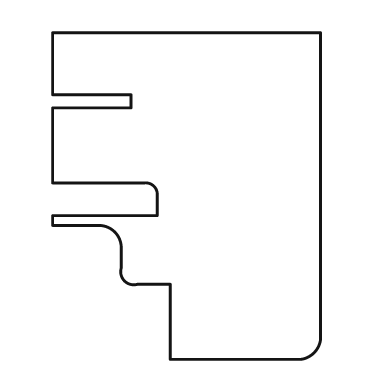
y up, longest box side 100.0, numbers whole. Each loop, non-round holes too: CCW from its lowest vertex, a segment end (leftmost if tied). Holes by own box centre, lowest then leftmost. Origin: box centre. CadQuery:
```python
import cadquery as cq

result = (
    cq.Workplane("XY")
    .moveTo(-5.0, -50.0)
    .lineTo(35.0, -50.0)
    .threePointArc((39.0, -48.0), (41.0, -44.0))
    .lineTo(41.0, 50.0)
    .lineTo(-41.0, 50.0)
    .lineTo(-41.0, 31.0)
    .lineTo(-17.0, 31.0)
    .lineTo(-17.0, 27.0)
    .lineTo(-41.0, 27.0)
    .lineTo(-41.0, 4.0)
    .lineTo(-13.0, 4.0)
    .threePointArc((-10.0, 3.0), (-9.0, 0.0))
    .lineTo(-9.0, -6.0)
    .lineTo(-41.0, -6.0)
    .lineTo(-41.0, -9.0)
    .lineTo(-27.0, -9.0)
    .threePointArc((-22.0, -11.0), (-20.0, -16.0))
    .lineTo(-20.0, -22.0)
    .threePointArc((-19.0, -26.0), (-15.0, -27.0))
    .lineTo(-5.0, -27.0)
    .close()
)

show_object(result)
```